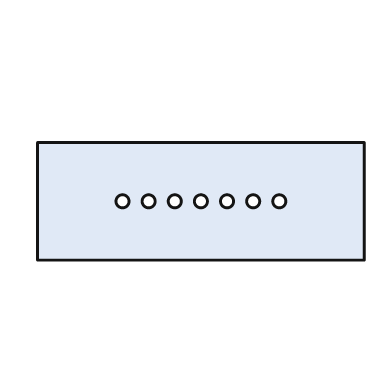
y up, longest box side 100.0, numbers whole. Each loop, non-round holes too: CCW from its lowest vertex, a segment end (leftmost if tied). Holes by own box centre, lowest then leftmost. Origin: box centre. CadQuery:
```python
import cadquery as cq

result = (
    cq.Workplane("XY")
    .moveTo(-50.0, -18.0)
    .lineTo(50.0, -18.0)
    .lineTo(50.0, 18.0)
    .lineTo(-50.0, 18.0)
    .close()
    .moveTo(-24.0, 0.0)
    .circle(2.0)
    .moveTo(-16.0, 0.0)
    .circle(2.0)
    .moveTo(-8.0, 0.0)
    .circle(2.0)
    .moveTo(0.0, 0.0)
    .circle(2.0)
    .moveTo(8.0, 0.0)
    .circle(2.0)
    .moveTo(16.0, 0.0)
    .circle(2.0)
    .moveTo(24.0, 0.0)
    .circle(2.0)
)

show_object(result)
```